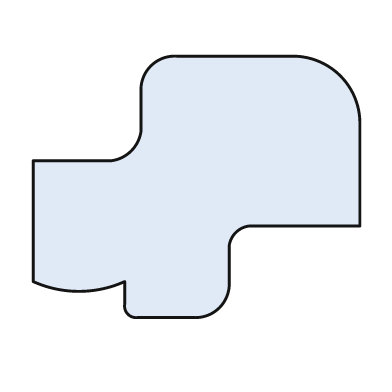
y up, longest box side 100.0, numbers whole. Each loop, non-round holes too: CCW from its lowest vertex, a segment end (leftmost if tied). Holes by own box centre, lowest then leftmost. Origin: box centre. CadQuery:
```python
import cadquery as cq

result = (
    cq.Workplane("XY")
    .moveTo(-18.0, -40.0)
    .lineTo(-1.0, -40.0)
    .threePointArc((7.0, -37.0), (10.0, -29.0))
    .lineTo(10.0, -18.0)
    .threePointArc((12.0, -14.0), (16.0, -12.0))
    .lineTo(50.0, -12.0)
    .lineTo(50.0, 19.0)
    .threePointArc((44.0, 34.0), (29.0, 40.0))
    .lineTo(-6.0, 40.0)
    .threePointArc((-14.0, 37.0), (-17.0, 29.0))
    .lineTo(-17.0, 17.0)
    .threePointArc((-20.0, 11.0), (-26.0, 8.0))
    .lineTo(-50.0, 8.0)
    .lineTo(-50.0, -29.0)
    .threePointArc((-36.0, -32.0), (-22.0, -29.0))
    .lineTo(-22.0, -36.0)
    .threePointArc((-21.0, -39.0), (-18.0, -40.0))
    .close()
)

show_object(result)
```